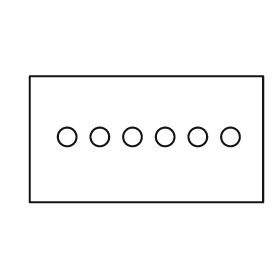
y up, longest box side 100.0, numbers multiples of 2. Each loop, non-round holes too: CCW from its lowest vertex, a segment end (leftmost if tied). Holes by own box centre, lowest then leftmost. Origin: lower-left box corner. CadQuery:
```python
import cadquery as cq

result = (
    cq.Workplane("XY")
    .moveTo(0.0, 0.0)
    .lineTo(100.0, 0.0)
    .lineTo(100.0, 54.0)
    .lineTo(0.0, 54.0)
    .close()
    .moveTo(16.0, 28.0)
    .circle(4.0)
    .moveTo(30.0, 28.0)
    .circle(4.0)
    .moveTo(44.0, 28.0)
    .circle(4.0)
    .moveTo(58.0, 28.0)
    .circle(4.0)
    .moveTo(72.0, 28.0)
    .circle(4.0)
    .moveTo(86.0, 28.0)
    .circle(4.0)
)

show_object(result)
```